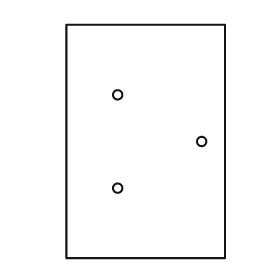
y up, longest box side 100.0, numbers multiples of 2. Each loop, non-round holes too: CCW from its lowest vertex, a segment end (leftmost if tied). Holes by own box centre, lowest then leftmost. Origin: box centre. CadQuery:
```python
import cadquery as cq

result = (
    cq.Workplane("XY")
    .moveTo(-34.0, -50.0)
    .lineTo(34.0, -50.0)
    .lineTo(34.0, 50.0)
    .lineTo(-34.0, 50.0)
    .close()
    .moveTo(-12.0, -20.0)
    .circle(2.0)
    .moveTo(24.0, 0.0)
    .circle(2.0)
    .moveTo(-12.0, 20.0)
    .circle(2.0)
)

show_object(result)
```